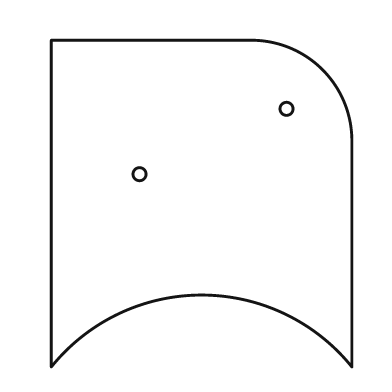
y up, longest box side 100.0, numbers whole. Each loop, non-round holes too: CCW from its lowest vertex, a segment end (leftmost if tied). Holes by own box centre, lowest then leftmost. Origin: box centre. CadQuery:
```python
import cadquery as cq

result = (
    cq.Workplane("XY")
    .moveTo(-46.0, -50.0)
    .threePointArc((0.0, -28.0), (46.0, -50.0))
    .lineTo(46.0, 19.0)
    .threePointArc((37.0, 41.0), (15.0, 50.0))
    .lineTo(-46.0, 50.0)
    .close()
    .moveTo(-19.0, 9.0)
    .circle(2.0)
    .moveTo(26.0, 29.0)
    .circle(2.0)
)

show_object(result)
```